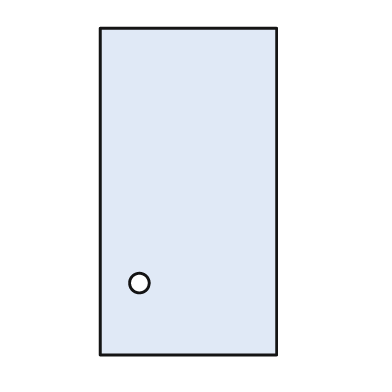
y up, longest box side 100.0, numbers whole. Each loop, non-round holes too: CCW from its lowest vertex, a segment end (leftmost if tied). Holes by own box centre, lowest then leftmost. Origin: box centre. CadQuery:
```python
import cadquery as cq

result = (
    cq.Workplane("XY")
    .moveTo(-27.0, -50.0)
    .lineTo(27.0, -50.0)
    .lineTo(27.0, 50.0)
    .lineTo(-27.0, 50.0)
    .close()
    .moveTo(-15.0, -28.0)
    .circle(3.0)
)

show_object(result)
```